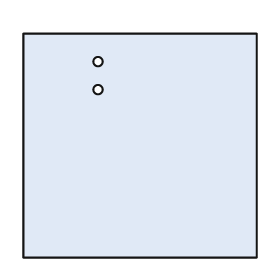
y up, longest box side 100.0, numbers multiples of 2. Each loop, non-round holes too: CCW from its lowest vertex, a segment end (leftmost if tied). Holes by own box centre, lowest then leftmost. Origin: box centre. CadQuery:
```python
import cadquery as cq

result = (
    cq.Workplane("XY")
    .moveTo(-50.0, -48.0)
    .lineTo(50.0, -48.0)
    .lineTo(50.0, 48.0)
    .lineTo(-50.0, 48.0)
    .close()
    .moveTo(-18.0, 24.0)
    .circle(2.0)
    .moveTo(-18.0, 36.0)
    .circle(2.0)
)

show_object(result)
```